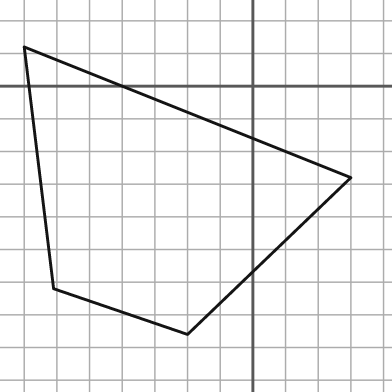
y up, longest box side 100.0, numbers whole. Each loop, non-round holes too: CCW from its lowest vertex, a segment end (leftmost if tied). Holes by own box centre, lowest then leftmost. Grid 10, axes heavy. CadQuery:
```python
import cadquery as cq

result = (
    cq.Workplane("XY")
    .moveTo(-20.0, -76.0)
    .lineTo(30.0, -28.0)
    .lineTo(-70.0, 12.0)
    .lineTo(-61.0, -62.0)
    .close()
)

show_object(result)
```